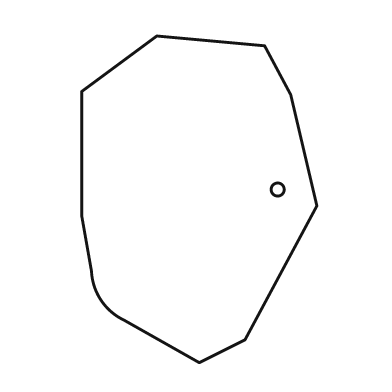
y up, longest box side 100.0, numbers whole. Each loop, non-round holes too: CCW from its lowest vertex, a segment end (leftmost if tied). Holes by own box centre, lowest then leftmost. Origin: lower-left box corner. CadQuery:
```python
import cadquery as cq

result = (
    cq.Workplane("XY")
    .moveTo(36.0, 0.0)
    .lineTo(50.0, 7.0)
    .lineTo(72.0, 48.0)
    .lineTo(64.0, 82.0)
    .lineTo(56.0, 97.0)
    .lineTo(23.0, 100.0)
    .lineTo(0.0, 83.0)
    .lineTo(0.0, 45.0)
    .lineTo(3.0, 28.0)
    .threePointArc((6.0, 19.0), (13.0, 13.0))
    .close()
    .moveTo(60.0, 53.0)
    .circle(2.0)
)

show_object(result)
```